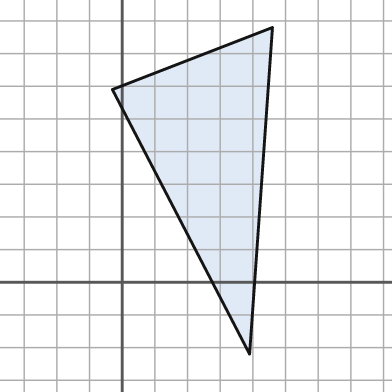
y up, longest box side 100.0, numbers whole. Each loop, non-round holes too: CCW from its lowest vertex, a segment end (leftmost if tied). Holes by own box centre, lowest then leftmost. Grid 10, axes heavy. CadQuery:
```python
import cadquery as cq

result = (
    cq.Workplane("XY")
    .moveTo(39.0, -22.0)
    .lineTo(46.0, 78.0)
    .lineTo(-3.0, 59.0)
    .close()
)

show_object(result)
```